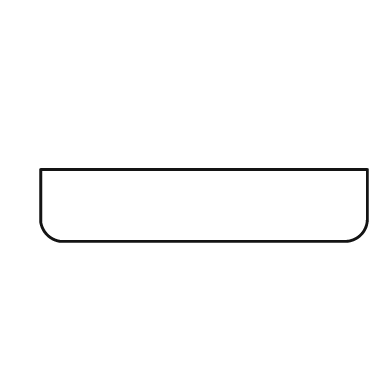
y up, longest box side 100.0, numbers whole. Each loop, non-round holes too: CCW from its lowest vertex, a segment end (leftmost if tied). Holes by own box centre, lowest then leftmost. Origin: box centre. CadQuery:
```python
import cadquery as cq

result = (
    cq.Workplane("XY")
    .moveTo(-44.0, -11.0)
    .lineTo(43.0, -11.0)
    .threePointArc((48.0, -9.0), (50.0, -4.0))
    .lineTo(50.0, 11.0)
    .lineTo(-50.0, 11.0)
    .lineTo(-50.0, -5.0)
    .threePointArc((-48.0, -9.0), (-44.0, -11.0))
    .close()
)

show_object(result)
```